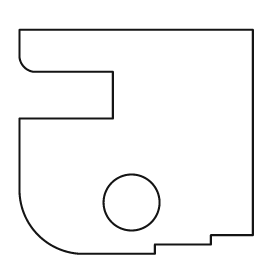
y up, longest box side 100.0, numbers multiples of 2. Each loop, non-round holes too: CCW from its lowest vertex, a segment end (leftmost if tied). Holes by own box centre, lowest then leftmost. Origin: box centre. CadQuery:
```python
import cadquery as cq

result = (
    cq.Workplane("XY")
    .moveTo(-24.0, -48.0)
    .lineTo(8.0, -48.0)
    .lineTo(8.0, -44.0)
    .lineTo(32.0, -44.0)
    .lineTo(32.0, -40.0)
    .lineTo(50.0, -40.0)
    .lineTo(50.0, 48.0)
    .lineTo(-50.0, 48.0)
    .lineTo(-50.0, 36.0)
    .threePointArc((-48.0, 32.0), (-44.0, 30.0))
    .lineTo(-10.0, 30.0)
    .lineTo(-10.0, 10.0)
    .lineTo(-50.0, 10.0)
    .lineTo(-50.0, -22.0)
    .threePointArc((-42.0, -40.0), (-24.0, -48.0))
    .close()
    .moveTo(-2.0, -26.0)
    .circle(12.0)
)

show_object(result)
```